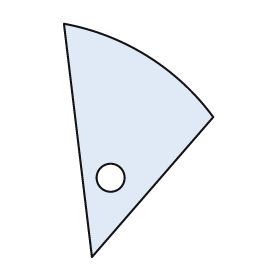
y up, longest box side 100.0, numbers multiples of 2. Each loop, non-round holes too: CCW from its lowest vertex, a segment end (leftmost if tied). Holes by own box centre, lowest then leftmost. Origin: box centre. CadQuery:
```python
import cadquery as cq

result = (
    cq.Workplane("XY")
    .moveTo(-20.0, -50.0)
    .lineTo(32.0, 10.0)
    .threePointArc((4.0, 36.0), (-32.0, 50.0))
    .close()
    .moveTo(-12.0, -16.0)
    .circle(6.0)
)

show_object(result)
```